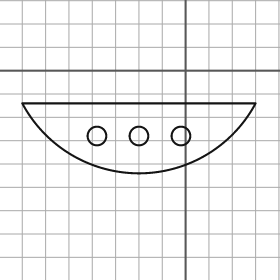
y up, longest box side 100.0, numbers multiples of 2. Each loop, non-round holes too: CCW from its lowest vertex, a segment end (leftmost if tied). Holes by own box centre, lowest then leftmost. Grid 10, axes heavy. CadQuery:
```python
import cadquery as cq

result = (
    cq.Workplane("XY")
    .moveTo(-70.0, -14.0)
    .threePointArc((-20.0, -44.0), (30.0, -14.0))
    .close()
    .moveTo(-38.0, -28.0)
    .circle(4.0)
    .moveTo(-20.0, -28.0)
    .circle(4.0)
    .moveTo(-2.0, -28.0)
    .circle(4.0)
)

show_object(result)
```